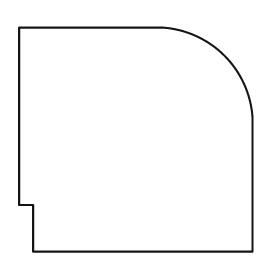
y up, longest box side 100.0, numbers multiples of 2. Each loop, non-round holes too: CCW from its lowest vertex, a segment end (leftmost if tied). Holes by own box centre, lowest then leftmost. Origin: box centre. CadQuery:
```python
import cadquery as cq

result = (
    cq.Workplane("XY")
    .moveTo(-44.0, -48.0)
    .lineTo(50.0, -48.0)
    .lineTo(50.0, 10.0)
    .threePointArc((38.0, 36.0), (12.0, 48.0))
    .lineTo(-50.0, 48.0)
    .lineTo(-50.0, -28.0)
    .lineTo(-44.0, -28.0)
    .close()
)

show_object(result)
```